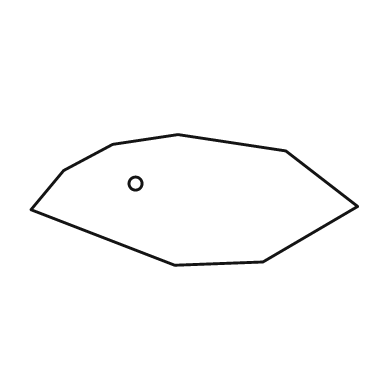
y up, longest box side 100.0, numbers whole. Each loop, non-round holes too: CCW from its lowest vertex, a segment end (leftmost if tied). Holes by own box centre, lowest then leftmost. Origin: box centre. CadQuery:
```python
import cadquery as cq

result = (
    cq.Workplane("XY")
    .moveTo(-6.0, -20.0)
    .lineTo(21.0, -19.0)
    .lineTo(50.0, -2.0)
    .lineTo(28.0, 15.0)
    .lineTo(-5.0, 20.0)
    .lineTo(-25.0, 17.0)
    .lineTo(-40.0, 9.0)
    .lineTo(-50.0, -3.0)
    .close()
    .moveTo(-18.0, 5.0)
    .circle(2.0)
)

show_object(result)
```